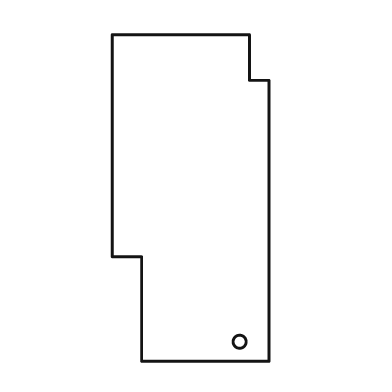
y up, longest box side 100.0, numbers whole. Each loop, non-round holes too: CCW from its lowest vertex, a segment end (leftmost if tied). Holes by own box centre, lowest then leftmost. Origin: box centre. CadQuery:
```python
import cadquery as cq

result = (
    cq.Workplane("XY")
    .moveTo(-15.0, -50.0)
    .lineTo(24.0, -50.0)
    .lineTo(24.0, 36.0)
    .lineTo(18.0, 36.0)
    .lineTo(18.0, 50.0)
    .lineTo(-24.0, 50.0)
    .lineTo(-24.0, -18.0)
    .lineTo(-15.0, -18.0)
    .close()
    .moveTo(15.0, -44.0)
    .circle(2.0)
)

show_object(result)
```